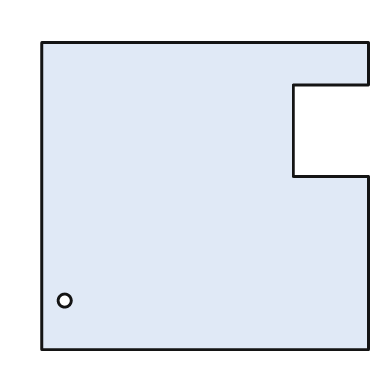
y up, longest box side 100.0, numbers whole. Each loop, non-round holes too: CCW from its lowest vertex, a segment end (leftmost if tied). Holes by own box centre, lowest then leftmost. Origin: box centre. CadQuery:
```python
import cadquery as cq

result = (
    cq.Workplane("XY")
    .moveTo(-50.0, -47.0)
    .lineTo(50.0, -47.0)
    .lineTo(50.0, 6.0)
    .lineTo(27.0, 6.0)
    .lineTo(27.0, 34.0)
    .lineTo(50.0, 34.0)
    .lineTo(50.0, 47.0)
    .lineTo(-50.0, 47.0)
    .close()
    .moveTo(-43.0, -32.0)
    .circle(2.0)
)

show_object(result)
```